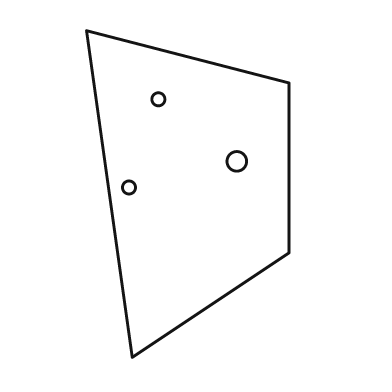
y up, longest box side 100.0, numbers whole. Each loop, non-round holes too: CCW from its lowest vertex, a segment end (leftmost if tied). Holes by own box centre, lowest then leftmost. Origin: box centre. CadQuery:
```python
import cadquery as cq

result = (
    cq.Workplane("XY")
    .moveTo(-17.0, -50.0)
    .lineTo(31.0, -18.0)
    .lineTo(31.0, 34.0)
    .lineTo(-31.0, 50.0)
    .close()
    .moveTo(-18.0, 2.0)
    .circle(2.0)
    .moveTo(15.0, 10.0)
    .circle(3.0)
    .moveTo(-9.0, 29.0)
    .circle(2.0)
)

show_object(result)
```